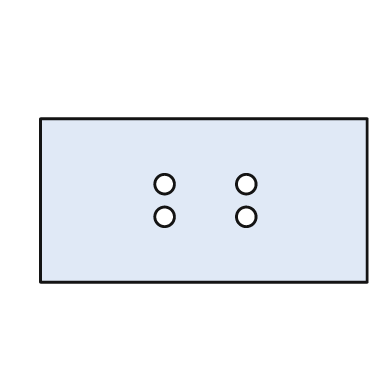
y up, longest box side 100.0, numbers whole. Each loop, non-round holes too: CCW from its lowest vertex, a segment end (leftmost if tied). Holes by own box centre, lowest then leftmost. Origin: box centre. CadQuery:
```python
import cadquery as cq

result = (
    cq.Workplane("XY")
    .moveTo(-50.0, -25.0)
    .lineTo(50.0, -25.0)
    .lineTo(50.0, 25.0)
    .lineTo(-50.0, 25.0)
    .close()
    .moveTo(-12.0, -5.0)
    .circle(3.0)
    .moveTo(13.0, -5.0)
    .circle(3.0)
    .moveTo(-12.0, 5.0)
    .circle(3.0)
    .moveTo(13.0, 5.0)
    .circle(3.0)
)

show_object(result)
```